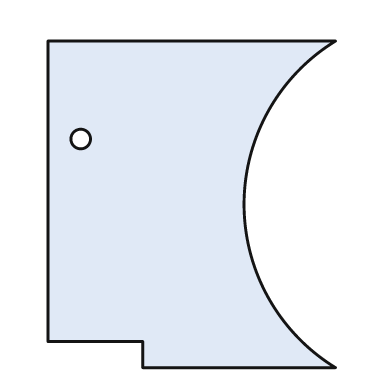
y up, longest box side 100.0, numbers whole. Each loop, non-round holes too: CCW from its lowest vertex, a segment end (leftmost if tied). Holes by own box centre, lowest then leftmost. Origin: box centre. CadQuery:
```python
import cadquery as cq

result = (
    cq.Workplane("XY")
    .moveTo(-15.0, -50.0)
    .lineTo(44.0, -50.0)
    .threePointArc((16.0, 0.0), (44.0, 50.0))
    .lineTo(-44.0, 50.0)
    .lineTo(-44.0, -42.0)
    .lineTo(-15.0, -42.0)
    .close()
    .moveTo(-34.0, 20.0)
    .circle(3.0)
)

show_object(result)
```